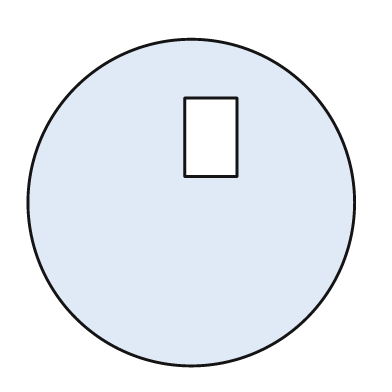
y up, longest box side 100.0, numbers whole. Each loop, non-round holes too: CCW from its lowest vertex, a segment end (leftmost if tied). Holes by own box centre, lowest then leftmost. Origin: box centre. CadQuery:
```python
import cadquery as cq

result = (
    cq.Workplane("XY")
    .moveTo(0.0, 0.0)
    .circle(50.0)
    .moveTo(-2.0, 8.0)
    .lineTo(14.0, 8.0)
    .lineTo(14.0, 32.0)
    .lineTo(-2.0, 32.0)
    .close()
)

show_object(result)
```